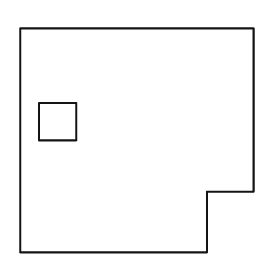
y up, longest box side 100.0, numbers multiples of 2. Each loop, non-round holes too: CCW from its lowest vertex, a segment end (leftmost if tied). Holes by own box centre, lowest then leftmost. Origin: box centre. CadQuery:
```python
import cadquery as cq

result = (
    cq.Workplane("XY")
    .moveTo(-50.0, -48.0)
    .lineTo(30.0, -48.0)
    .lineTo(30.0, -22.0)
    .lineTo(50.0, -22.0)
    .lineTo(50.0, 48.0)
    .lineTo(-50.0, 48.0)
    .close()
    .moveTo(-42.0, 0.0)
    .lineTo(-26.0, 0.0)
    .lineTo(-26.0, 16.0)
    .lineTo(-42.0, 16.0)
    .close()
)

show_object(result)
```